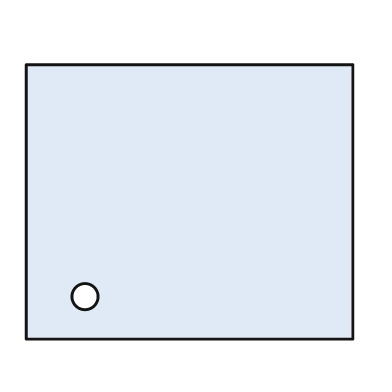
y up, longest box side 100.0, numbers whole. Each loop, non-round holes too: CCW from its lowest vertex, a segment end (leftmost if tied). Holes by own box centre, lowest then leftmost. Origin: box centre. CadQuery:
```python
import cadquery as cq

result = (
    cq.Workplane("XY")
    .moveTo(-50.0, -42.0)
    .lineTo(50.0, -42.0)
    .lineTo(50.0, 42.0)
    .lineTo(-50.0, 42.0)
    .close()
    .moveTo(-32.0, -29.0)
    .circle(4.0)
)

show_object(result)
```